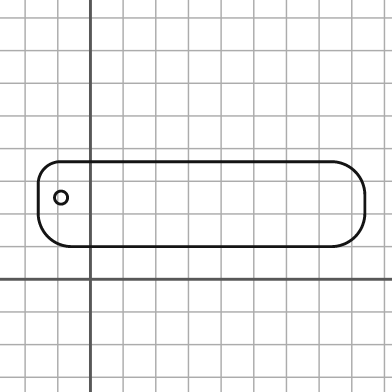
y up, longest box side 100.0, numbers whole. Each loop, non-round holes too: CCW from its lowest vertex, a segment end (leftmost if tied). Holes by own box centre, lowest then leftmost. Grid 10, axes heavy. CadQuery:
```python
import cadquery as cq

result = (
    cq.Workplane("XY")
    .moveTo(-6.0, 10.0)
    .lineTo(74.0, 10.0)
    .threePointArc((81.0, 13.0), (84.0, 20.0))
    .lineTo(84.0, 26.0)
    .threePointArc((81.0, 33.0), (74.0, 36.0))
    .lineTo(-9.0, 36.0)
    .threePointArc((-14.0, 34.0), (-16.0, 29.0))
    .lineTo(-16.0, 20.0)
    .threePointArc((-13.0, 13.0), (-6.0, 10.0))
    .close()
    .moveTo(-9.0, 25.0)
    .circle(2.0)
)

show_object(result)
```